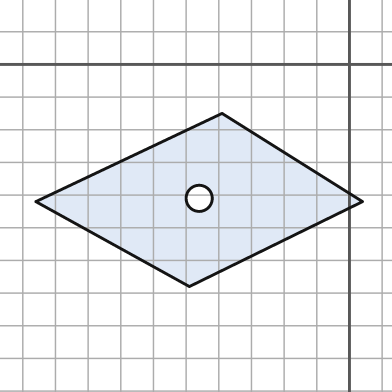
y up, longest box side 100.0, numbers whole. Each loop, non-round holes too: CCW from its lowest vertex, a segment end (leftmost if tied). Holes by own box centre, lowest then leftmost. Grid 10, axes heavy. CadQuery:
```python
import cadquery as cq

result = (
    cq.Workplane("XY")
    .moveTo(-49.0, -68.0)
    .lineTo(4.0, -42.0)
    .lineTo(-39.0, -15.0)
    .lineTo(-96.0, -42.0)
    .close()
    .moveTo(-46.0, -41.0)
    .circle(4.0)
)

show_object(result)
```